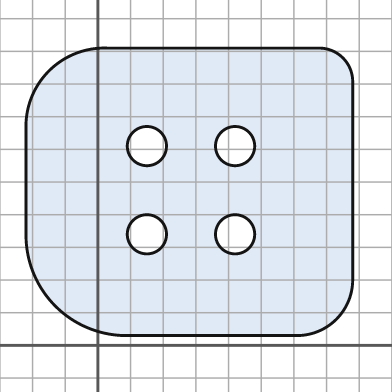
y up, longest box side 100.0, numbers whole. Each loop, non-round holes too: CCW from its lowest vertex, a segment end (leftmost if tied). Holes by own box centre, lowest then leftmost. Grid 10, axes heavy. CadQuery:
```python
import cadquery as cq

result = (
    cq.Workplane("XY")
    .moveTo(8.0, 3.0)
    .lineTo(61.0, 3.0)
    .threePointArc((73.0, 8.0), (78.0, 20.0))
    .lineTo(78.0, 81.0)
    .threePointArc((75.0, 88.0), (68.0, 91.0))
    .lineTo(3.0, 91.0)
    .threePointArc((-15.0, 84.0), (-22.0, 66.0))
    .lineTo(-22.0, 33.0)
    .threePointArc((-13.0, 12.0), (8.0, 3.0))
    .close()
    .moveTo(15.0, 34.0)
    .circle(6.0)
    .moveTo(42.0, 34.0)
    .circle(6.0)
    .moveTo(15.0, 61.0)
    .circle(6.0)
    .moveTo(42.0, 61.0)
    .circle(6.0)
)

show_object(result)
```